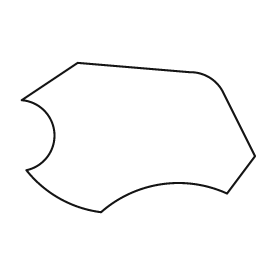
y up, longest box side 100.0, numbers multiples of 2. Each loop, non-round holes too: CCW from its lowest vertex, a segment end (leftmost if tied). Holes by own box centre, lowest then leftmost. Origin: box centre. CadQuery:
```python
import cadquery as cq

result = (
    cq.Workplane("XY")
    .moveTo(-16.0, -32.0)
    .threePointArc((10.0, -20.0), (38.0, -24.0))
    .lineTo(50.0, -8.0)
    .lineTo(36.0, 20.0)
    .threePointArc((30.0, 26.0), (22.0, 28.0))
    .lineTo(-26.0, 32.0)
    .lineTo(-50.0, 16.0)
    .threePointArc((-36.0, 2.0), (-48.0, -14.0))
    .threePointArc((-34.0, -26.0), (-16.0, -32.0))
    .close()
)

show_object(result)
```